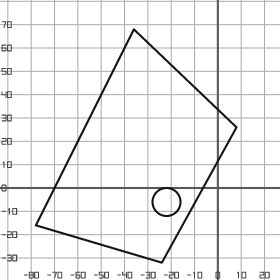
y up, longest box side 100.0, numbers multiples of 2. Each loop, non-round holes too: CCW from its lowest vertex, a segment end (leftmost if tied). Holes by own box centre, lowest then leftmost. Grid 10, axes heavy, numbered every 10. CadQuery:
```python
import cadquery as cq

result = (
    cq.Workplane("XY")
    .moveTo(-24.0, -32.0)
    .lineTo(8.0, 26.0)
    .lineTo(-36.0, 68.0)
    .lineTo(-78.0, -16.0)
    .close()
    .moveTo(-22.0, -6.0)
    .circle(6.0)
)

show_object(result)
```